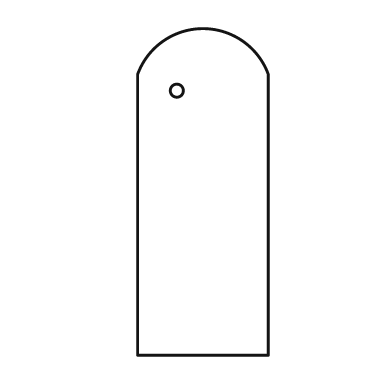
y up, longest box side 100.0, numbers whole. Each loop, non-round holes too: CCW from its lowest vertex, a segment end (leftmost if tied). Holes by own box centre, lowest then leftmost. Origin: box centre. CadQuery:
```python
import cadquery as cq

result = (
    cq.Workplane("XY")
    .moveTo(-20.0, -50.0)
    .lineTo(20.0, -50.0)
    .lineTo(20.0, 36.0)
    .threePointArc((0.0, 50.0), (-20.0, 36.0))
    .close()
    .moveTo(-8.0, 31.0)
    .circle(2.0)
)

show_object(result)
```